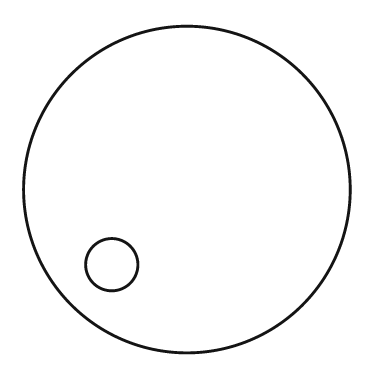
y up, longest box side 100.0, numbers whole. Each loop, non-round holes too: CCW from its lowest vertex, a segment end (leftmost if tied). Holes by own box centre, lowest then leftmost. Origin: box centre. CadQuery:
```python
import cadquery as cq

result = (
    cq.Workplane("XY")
    .moveTo(0.0, 0.0)
    .circle(50.0)
    .moveTo(-23.0, -23.0)
    .circle(8.0)
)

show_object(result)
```